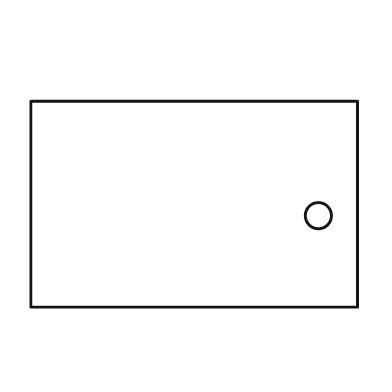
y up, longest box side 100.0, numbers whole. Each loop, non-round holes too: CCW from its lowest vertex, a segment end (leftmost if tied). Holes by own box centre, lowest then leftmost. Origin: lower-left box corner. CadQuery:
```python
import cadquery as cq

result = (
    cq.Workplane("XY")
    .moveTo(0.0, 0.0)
    .lineTo(100.0, 0.0)
    .lineTo(100.0, 63.0)
    .lineTo(0.0, 63.0)
    .close()
    .moveTo(88.0, 28.0)
    .circle(4.0)
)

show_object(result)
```